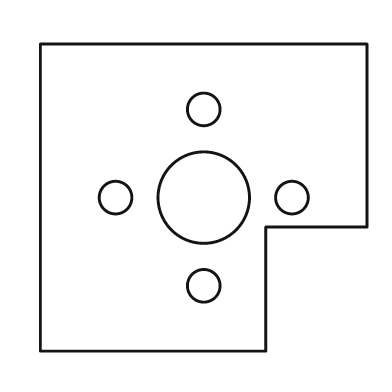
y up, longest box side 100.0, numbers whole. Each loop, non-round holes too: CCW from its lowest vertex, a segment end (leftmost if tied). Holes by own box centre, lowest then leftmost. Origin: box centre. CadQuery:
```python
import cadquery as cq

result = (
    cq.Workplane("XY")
    .moveTo(-50.0, -47.0)
    .lineTo(19.0, -47.0)
    .lineTo(19.0, -9.0)
    .lineTo(50.0, -9.0)
    .lineTo(50.0, 47.0)
    .lineTo(-50.0, 47.0)
    .close()
    .moveTo(0.0, -27.0)
    .circle(5.0)
    .moveTo(-27.0, 0.0)
    .circle(5.0)
    .moveTo(0.0, 0.0)
    .circle(14.0)
    .moveTo(27.0, 0.0)
    .circle(5.0)
    .moveTo(0.0, 27.0)
    .circle(5.0)
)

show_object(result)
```